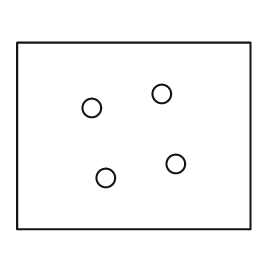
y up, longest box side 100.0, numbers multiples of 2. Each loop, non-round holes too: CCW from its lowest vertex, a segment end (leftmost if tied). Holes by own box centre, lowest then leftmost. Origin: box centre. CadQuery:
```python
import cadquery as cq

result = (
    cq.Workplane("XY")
    .moveTo(-50.0, -40.0)
    .lineTo(50.0, -40.0)
    .lineTo(50.0, 40.0)
    .lineTo(-50.0, 40.0)
    .close()
    .moveTo(-12.0, -18.0)
    .circle(4.0)
    .moveTo(18.0, -12.0)
    .circle(4.0)
    .moveTo(-18.0, 12.0)
    .circle(4.0)
    .moveTo(12.0, 18.0)
    .circle(4.0)
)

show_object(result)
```